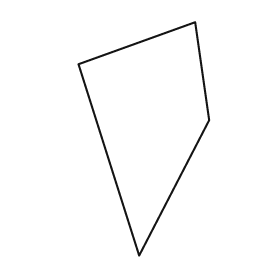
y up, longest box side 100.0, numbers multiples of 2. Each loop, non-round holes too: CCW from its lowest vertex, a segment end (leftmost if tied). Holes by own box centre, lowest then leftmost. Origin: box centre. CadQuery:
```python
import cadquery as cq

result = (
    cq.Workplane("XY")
    .moveTo(-2.0, -50.0)
    .lineTo(28.0, 8.0)
    .lineTo(22.0, 50.0)
    .lineTo(-28.0, 32.0)
    .close()
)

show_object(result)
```